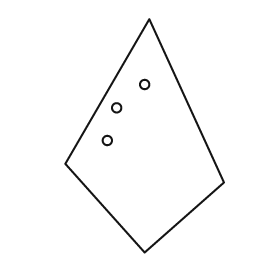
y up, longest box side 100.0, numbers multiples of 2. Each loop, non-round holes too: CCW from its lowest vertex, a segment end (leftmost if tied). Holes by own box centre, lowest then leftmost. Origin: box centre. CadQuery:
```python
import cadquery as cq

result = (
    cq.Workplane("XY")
    .moveTo(0.0, -50.0)
    .lineTo(34.0, -20.0)
    .lineTo(2.0, 50.0)
    .lineTo(-34.0, -12.0)
    .close()
    .moveTo(-16.0, -2.0)
    .circle(2.0)
    .moveTo(-12.0, 12.0)
    .circle(2.0)
    .moveTo(0.0, 22.0)
    .circle(2.0)
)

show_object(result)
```